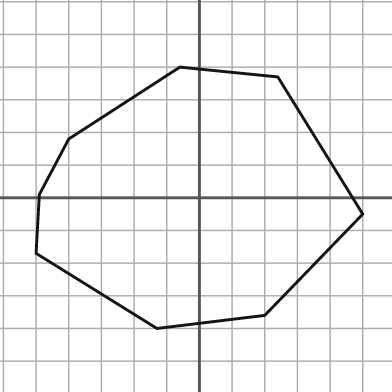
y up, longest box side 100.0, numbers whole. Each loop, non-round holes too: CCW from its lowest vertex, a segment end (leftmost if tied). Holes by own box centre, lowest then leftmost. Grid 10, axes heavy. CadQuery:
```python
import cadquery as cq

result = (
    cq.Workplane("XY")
    .moveTo(-13.0, -40.0)
    .lineTo(20.0, -36.0)
    .lineTo(50.0, -5.0)
    .lineTo(24.0, 37.0)
    .lineTo(-6.0, 40.0)
    .lineTo(-40.0, 18.0)
    .lineTo(-49.0, 1.0)
    .lineTo(-50.0, -17.0)
    .close()
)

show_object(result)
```